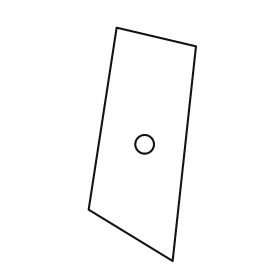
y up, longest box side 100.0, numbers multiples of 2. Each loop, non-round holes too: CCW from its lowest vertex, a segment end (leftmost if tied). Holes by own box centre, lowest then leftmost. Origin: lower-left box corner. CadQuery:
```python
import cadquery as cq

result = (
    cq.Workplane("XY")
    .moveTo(36.0, 0.0)
    .lineTo(46.0, 92.0)
    .lineTo(12.0, 100.0)
    .lineTo(0.0, 22.0)
    .close()
    .moveTo(24.0, 50.0)
    .circle(4.0)
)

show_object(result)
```